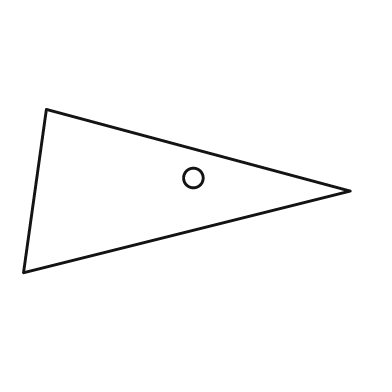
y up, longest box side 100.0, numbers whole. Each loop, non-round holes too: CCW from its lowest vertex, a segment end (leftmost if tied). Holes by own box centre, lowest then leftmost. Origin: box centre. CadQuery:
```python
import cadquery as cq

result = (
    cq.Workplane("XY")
    .moveTo(-50.0, -25.0)
    .lineTo(50.0, 0.0)
    .lineTo(-43.0, 25.0)
    .close()
    .moveTo(2.0, 4.0)
    .circle(3.0)
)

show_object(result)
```